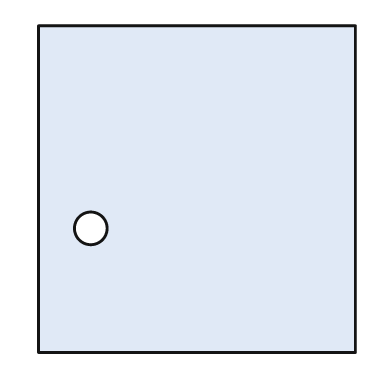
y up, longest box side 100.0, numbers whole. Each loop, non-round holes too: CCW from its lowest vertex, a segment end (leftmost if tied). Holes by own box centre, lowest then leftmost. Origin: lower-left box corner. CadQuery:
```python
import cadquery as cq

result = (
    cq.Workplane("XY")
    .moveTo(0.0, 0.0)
    .lineTo(97.0, 0.0)
    .lineTo(97.0, 100.0)
    .lineTo(0.0, 100.0)
    .close()
    .moveTo(16.0, 38.0)
    .circle(5.0)
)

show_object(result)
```